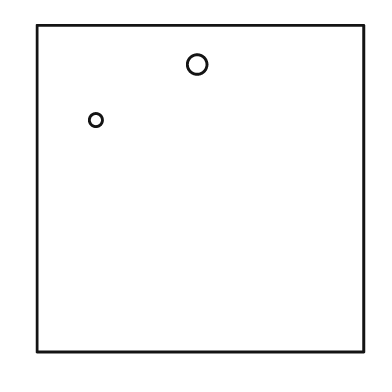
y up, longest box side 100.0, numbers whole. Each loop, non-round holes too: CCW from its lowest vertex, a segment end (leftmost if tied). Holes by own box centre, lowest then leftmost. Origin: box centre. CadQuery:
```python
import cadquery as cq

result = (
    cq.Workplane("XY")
    .moveTo(-50.0, -50.0)
    .lineTo(50.0, -50.0)
    .lineTo(50.0, 50.0)
    .lineTo(-50.0, 50.0)
    .close()
    .moveTo(-32.0, 21.0)
    .circle(2.0)
    .moveTo(-1.0, 38.0)
    .circle(3.0)
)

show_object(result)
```